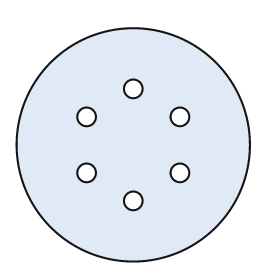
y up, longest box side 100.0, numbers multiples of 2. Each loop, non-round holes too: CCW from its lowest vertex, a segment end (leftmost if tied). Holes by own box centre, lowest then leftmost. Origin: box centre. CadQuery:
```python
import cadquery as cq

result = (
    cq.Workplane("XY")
    .moveTo(0.0, 0.0)
    .circle(50.0)
    .moveTo(0.0, -24.0)
    .circle(4.0)
    .moveTo(-20.0, -12.0)
    .circle(4.0)
    .moveTo(20.0, -12.0)
    .circle(4.0)
    .moveTo(-20.0, 12.0)
    .circle(4.0)
    .moveTo(20.0, 12.0)
    .circle(4.0)
    .moveTo(0.0, 24.0)
    .circle(4.0)
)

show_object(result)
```